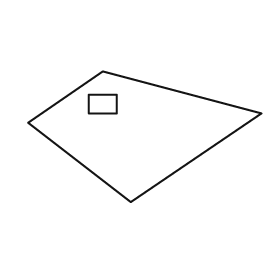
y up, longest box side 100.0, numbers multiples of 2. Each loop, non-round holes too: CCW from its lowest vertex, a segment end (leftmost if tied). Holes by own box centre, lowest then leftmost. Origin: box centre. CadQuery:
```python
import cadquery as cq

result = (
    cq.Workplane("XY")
    .moveTo(-6.0, -28.0)
    .lineTo(50.0, 10.0)
    .lineTo(-18.0, 28.0)
    .lineTo(-50.0, 6.0)
    .close()
    .moveTo(-24.0, 10.0)
    .lineTo(-12.0, 10.0)
    .lineTo(-12.0, 18.0)
    .lineTo(-24.0, 18.0)
    .close()
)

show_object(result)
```